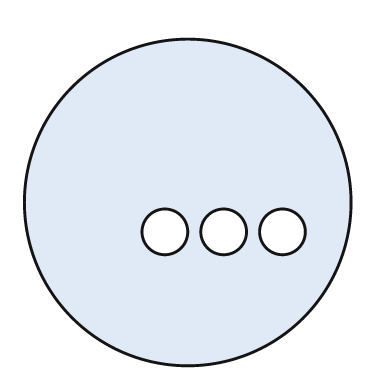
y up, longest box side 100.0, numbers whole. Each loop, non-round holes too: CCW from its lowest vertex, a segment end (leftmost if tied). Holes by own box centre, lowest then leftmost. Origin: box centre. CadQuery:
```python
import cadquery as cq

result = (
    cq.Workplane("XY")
    .moveTo(0.0, 0.0)
    .circle(50.0)
    .moveTo(-7.0, -9.0)
    .circle(7.0)
    .moveTo(11.0, -9.0)
    .circle(7.0)
    .moveTo(29.0, -9.0)
    .circle(7.0)
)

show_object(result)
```